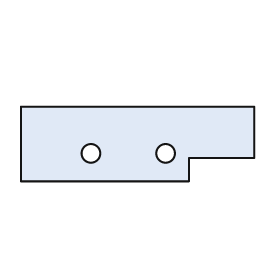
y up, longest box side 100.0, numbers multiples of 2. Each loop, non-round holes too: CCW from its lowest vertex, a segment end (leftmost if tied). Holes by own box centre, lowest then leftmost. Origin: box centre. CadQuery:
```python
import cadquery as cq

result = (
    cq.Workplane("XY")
    .moveTo(-50.0, -16.0)
    .lineTo(22.0, -16.0)
    .lineTo(22.0, -6.0)
    .lineTo(50.0, -6.0)
    .lineTo(50.0, 16.0)
    .lineTo(-50.0, 16.0)
    .close()
    .moveTo(-20.0, -4.0)
    .circle(4.0)
    .moveTo(12.0, -4.0)
    .circle(4.0)
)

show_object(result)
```